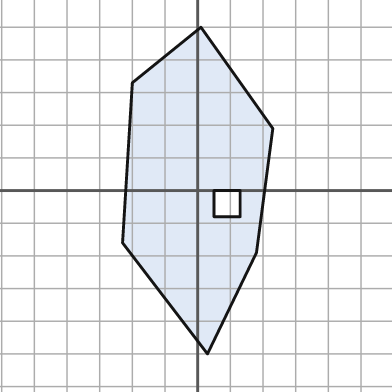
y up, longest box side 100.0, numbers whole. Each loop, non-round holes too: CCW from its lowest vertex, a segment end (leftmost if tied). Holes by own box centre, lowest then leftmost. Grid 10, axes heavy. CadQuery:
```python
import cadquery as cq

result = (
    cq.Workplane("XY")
    .moveTo(3.0, -50.0)
    .lineTo(18.0, -19.0)
    .lineTo(23.0, 19.0)
    .lineTo(1.0, 50.0)
    .lineTo(-20.0, 33.0)
    .lineTo(-23.0, -16.0)
    .close()
    .moveTo(5.0, -8.0)
    .lineTo(13.0, -8.0)
    .lineTo(13.0, 0.0)
    .lineTo(5.0, 0.0)
    .close()
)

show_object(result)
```